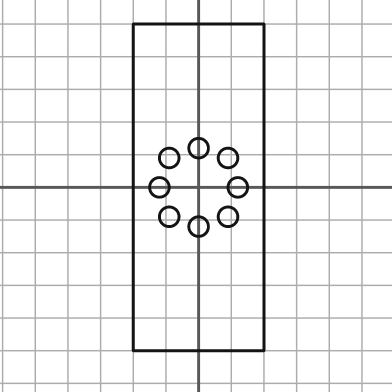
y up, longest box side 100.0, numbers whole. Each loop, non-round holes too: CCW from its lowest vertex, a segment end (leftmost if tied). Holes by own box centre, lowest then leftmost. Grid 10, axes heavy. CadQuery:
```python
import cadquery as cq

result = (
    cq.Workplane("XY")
    .moveTo(-20.0, -50.0)
    .lineTo(20.0, -50.0)
    .lineTo(20.0, 50.0)
    .lineTo(-20.0, 50.0)
    .close()
    .moveTo(0.0, -12.0)
    .circle(3.0)
    .moveTo(-9.0, -9.0)
    .circle(3.0)
    .moveTo(9.0, -9.0)
    .circle(3.0)
    .moveTo(-12.0, 0.0)
    .circle(3.0)
    .moveTo(12.0, 0.0)
    .circle(3.0)
    .moveTo(-9.0, 9.0)
    .circle(3.0)
    .moveTo(9.0, 9.0)
    .circle(3.0)
    .moveTo(0.0, 12.0)
    .circle(3.0)
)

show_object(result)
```